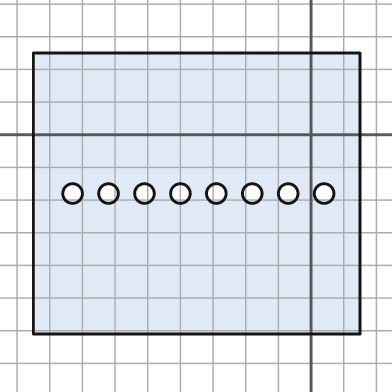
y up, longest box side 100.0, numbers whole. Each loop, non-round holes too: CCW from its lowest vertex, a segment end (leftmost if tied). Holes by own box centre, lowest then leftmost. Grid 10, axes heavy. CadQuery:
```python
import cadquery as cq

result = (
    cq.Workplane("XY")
    .moveTo(-85.0, -61.0)
    .lineTo(15.0, -61.0)
    .lineTo(15.0, 25.0)
    .lineTo(-85.0, 25.0)
    .close()
    .moveTo(-73.0, -18.0)
    .circle(3.0)
    .moveTo(-62.0, -18.0)
    .circle(3.0)
    .moveTo(-51.0, -18.0)
    .circle(3.0)
    .moveTo(-40.0, -18.0)
    .circle(3.0)
    .moveTo(-29.0, -18.0)
    .circle(3.0)
    .moveTo(-18.0, -18.0)
    .circle(3.0)
    .moveTo(-7.0, -18.0)
    .circle(3.0)
    .moveTo(4.0, -18.0)
    .circle(3.0)
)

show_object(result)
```